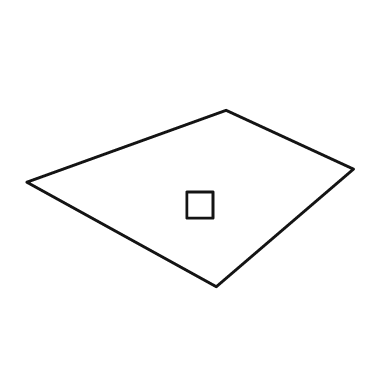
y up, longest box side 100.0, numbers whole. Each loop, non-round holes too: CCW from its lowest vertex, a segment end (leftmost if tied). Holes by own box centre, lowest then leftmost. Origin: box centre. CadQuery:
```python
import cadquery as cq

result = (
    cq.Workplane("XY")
    .moveTo(8.0, -27.0)
    .lineTo(50.0, 9.0)
    .lineTo(11.0, 27.0)
    .lineTo(-50.0, 5.0)
    .close()
    .moveTo(-1.0, -6.0)
    .lineTo(7.0, -6.0)
    .lineTo(7.0, 2.0)
    .lineTo(-1.0, 2.0)
    .close()
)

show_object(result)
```